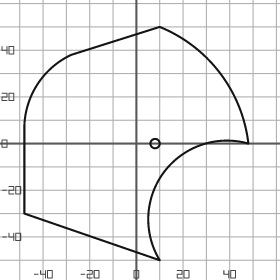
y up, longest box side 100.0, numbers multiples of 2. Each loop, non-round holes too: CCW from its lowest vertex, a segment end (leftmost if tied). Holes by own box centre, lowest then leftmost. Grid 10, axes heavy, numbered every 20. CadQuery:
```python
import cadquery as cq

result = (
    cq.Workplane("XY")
    .moveTo(10.0, -50.0)
    .threePointArc((12.0, -12.0), (48.0, 0.0))
    .threePointArc((36.0, 30.0), (10.0, 50.0))
    .lineTo(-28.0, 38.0)
    .threePointArc((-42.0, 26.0), (-48.0, 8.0))
    .lineTo(-48.0, -30.0)
    .close()
    .moveTo(8.0, 0.0)
    .circle(2.0)
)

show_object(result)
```